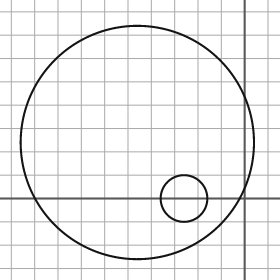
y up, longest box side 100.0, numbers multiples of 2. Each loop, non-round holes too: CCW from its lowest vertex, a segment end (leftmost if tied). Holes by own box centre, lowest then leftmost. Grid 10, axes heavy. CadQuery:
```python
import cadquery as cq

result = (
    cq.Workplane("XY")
    .moveTo(-46.0, 24.0)
    .circle(50.0)
    .moveTo(-26.0, 0.0)
    .circle(10.0)
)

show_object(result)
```